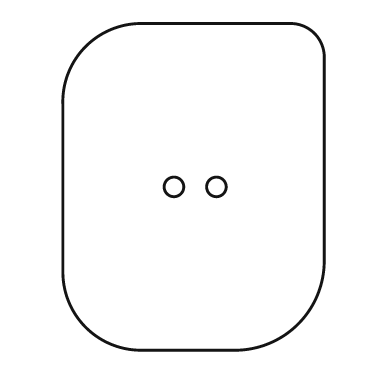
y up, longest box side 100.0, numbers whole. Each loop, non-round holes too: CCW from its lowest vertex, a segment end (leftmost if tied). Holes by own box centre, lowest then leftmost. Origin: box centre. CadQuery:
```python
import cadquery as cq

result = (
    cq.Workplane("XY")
    .moveTo(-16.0, -50.0)
    .lineTo(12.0, -50.0)
    .threePointArc((32.0, -42.0), (40.0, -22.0))
    .lineTo(40.0, 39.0)
    .threePointArc((37.0, 47.0), (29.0, 50.0))
    .lineTo(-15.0, 50.0)
    .threePointArc((-33.0, 43.0), (-40.0, 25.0))
    .lineTo(-40.0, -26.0)
    .threePointArc((-33.0, -43.0), (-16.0, -50.0))
    .close()
    .moveTo(-6.0, 0.0)
    .circle(3.0)
    .moveTo(7.0, 0.0)
    .circle(3.0)
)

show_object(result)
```